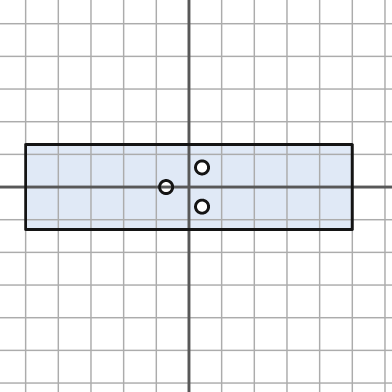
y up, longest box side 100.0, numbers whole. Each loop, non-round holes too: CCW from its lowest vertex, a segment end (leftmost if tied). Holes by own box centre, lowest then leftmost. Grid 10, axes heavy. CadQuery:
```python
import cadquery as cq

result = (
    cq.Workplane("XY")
    .moveTo(-50.0, -13.0)
    .lineTo(50.0, -13.0)
    .lineTo(50.0, 13.0)
    .lineTo(-50.0, 13.0)
    .close()
    .moveTo(4.0, -6.0)
    .circle(2.0)
    .moveTo(-7.0, 0.0)
    .circle(2.0)
    .moveTo(4.0, 6.0)
    .circle(2.0)
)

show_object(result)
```